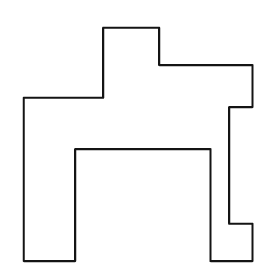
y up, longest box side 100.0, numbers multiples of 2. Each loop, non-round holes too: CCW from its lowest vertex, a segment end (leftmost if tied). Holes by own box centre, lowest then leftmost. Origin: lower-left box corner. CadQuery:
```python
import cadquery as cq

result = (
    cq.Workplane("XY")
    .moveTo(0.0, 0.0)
    .lineTo(22.0, 0.0)
    .lineTo(22.0, 48.0)
    .lineTo(80.0, 48.0)
    .lineTo(80.0, 0.0)
    .lineTo(98.0, 0.0)
    .lineTo(98.0, 16.0)
    .lineTo(88.0, 16.0)
    .lineTo(88.0, 66.0)
    .lineTo(98.0, 66.0)
    .lineTo(98.0, 84.0)
    .lineTo(58.0, 84.0)
    .lineTo(58.0, 100.0)
    .lineTo(34.0, 100.0)
    .lineTo(34.0, 70.0)
    .lineTo(0.0, 70.0)
    .close()
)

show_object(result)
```